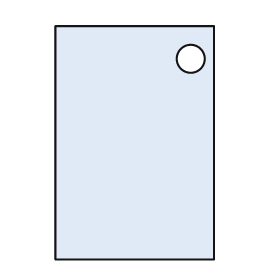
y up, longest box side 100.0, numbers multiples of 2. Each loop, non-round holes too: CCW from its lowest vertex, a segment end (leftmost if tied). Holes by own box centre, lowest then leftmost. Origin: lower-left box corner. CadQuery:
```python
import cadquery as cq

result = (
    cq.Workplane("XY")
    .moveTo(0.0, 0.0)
    .lineTo(68.0, 0.0)
    .lineTo(68.0, 100.0)
    .lineTo(0.0, 100.0)
    .close()
    .moveTo(58.0, 86.0)
    .circle(6.0)
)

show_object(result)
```